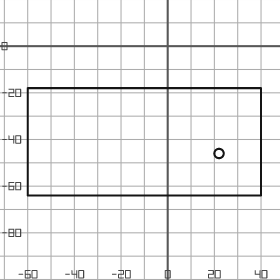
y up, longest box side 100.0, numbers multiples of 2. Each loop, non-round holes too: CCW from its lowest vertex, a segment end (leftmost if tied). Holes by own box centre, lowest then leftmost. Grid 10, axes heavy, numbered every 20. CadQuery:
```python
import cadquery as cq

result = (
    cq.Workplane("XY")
    .moveTo(-60.0, -64.0)
    .lineTo(40.0, -64.0)
    .lineTo(40.0, -18.0)
    .lineTo(-60.0, -18.0)
    .close()
    .moveTo(22.0, -46.0)
    .circle(2.0)
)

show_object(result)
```